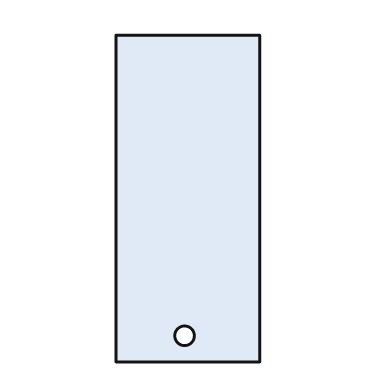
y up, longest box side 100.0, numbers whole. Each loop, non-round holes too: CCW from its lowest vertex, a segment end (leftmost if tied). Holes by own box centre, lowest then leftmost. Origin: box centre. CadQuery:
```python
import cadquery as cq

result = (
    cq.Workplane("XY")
    .moveTo(-22.0, -50.0)
    .lineTo(22.0, -50.0)
    .lineTo(22.0, 50.0)
    .lineTo(-22.0, 50.0)
    .close()
    .moveTo(-1.0, -42.0)
    .circle(3.0)
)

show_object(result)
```